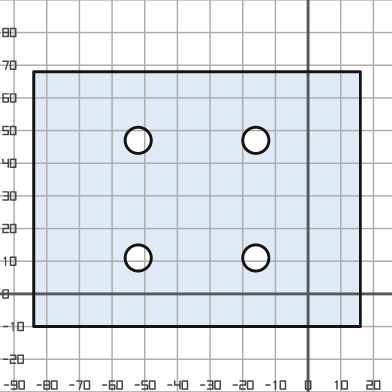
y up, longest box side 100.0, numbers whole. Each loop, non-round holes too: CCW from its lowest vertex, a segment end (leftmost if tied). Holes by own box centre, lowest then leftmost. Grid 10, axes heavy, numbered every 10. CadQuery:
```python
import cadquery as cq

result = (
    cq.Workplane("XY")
    .moveTo(-84.0, -10.0)
    .lineTo(16.0, -10.0)
    .lineTo(16.0, 68.0)
    .lineTo(-84.0, 68.0)
    .close()
    .moveTo(-52.0, 11.0)
    .circle(4.0)
    .moveTo(-16.0, 11.0)
    .circle(4.0)
    .moveTo(-52.0, 47.0)
    .circle(4.0)
    .moveTo(-16.0, 47.0)
    .circle(4.0)
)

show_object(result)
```